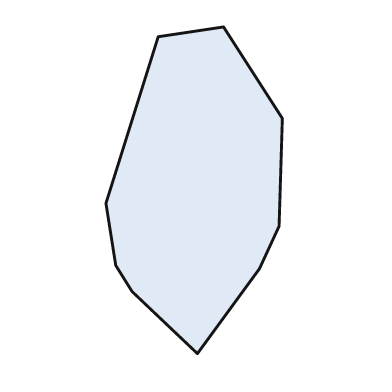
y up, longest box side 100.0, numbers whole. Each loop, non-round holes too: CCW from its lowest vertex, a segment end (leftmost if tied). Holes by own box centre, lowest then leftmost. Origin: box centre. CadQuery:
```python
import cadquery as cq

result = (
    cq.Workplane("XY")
    .moveTo(1.0, -50.0)
    .lineTo(20.0, -24.0)
    .lineTo(26.0, -11.0)
    .lineTo(27.0, 22.0)
    .lineTo(9.0, 50.0)
    .lineTo(-11.0, 47.0)
    .lineTo(-27.0, -4.0)
    .lineTo(-24.0, -23.0)
    .lineTo(-19.0, -31.0)
    .close()
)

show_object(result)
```